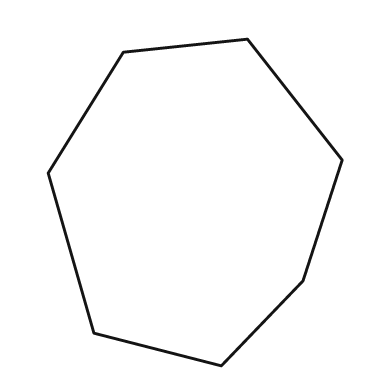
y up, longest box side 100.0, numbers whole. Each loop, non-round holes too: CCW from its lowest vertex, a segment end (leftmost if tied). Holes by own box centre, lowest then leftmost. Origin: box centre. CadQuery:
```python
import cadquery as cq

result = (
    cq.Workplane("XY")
    .moveTo(8.0, -50.0)
    .lineTo(33.0, -24.0)
    .lineTo(45.0, 13.0)
    .lineTo(16.0, 50.0)
    .lineTo(-22.0, 46.0)
    .lineTo(-45.0, 9.0)
    .lineTo(-31.0, -40.0)
    .close()
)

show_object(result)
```